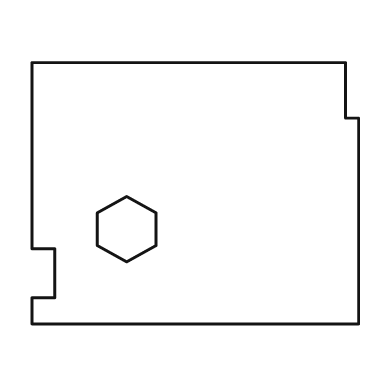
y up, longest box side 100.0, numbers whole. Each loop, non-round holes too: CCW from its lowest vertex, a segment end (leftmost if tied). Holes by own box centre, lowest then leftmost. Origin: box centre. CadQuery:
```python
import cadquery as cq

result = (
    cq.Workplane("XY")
    .moveTo(-50.0, -40.0)
    .lineTo(50.0, -40.0)
    .lineTo(50.0, 23.0)
    .lineTo(46.0, 23.0)
    .lineTo(46.0, 40.0)
    .lineTo(-50.0, 40.0)
    .lineTo(-50.0, -17.0)
    .lineTo(-43.0, -17.0)
    .lineTo(-43.0, -32.0)
    .lineTo(-50.0, -32.0)
    .close()
    .moveTo(-21.0, -21.0)
    .lineTo(-12.0, -16.0)
    .lineTo(-12.0, -6.0)
    .lineTo(-21.0, -1.0)
    .lineTo(-30.0, -6.0)
    .lineTo(-30.0, -16.0)
    .close()
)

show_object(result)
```